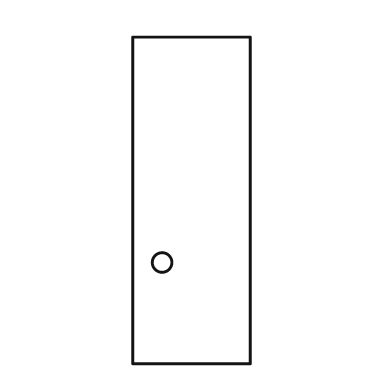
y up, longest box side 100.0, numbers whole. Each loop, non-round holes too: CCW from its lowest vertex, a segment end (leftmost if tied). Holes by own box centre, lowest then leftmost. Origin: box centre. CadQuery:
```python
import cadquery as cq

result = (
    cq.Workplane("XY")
    .moveTo(-18.0, -50.0)
    .lineTo(18.0, -50.0)
    .lineTo(18.0, 50.0)
    .lineTo(-18.0, 50.0)
    .close()
    .moveTo(-9.0, -19.0)
    .circle(3.0)
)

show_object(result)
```